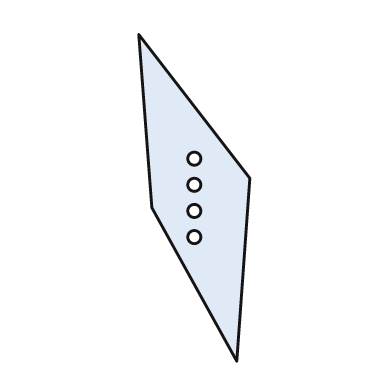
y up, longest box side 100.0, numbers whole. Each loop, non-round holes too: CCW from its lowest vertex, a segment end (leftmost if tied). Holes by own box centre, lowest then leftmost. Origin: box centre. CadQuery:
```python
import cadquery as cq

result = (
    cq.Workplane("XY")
    .moveTo(13.0, -50.0)
    .lineTo(17.0, 6.0)
    .lineTo(-17.0, 50.0)
    .lineTo(-13.0, -3.0)
    .close()
    .moveTo(0.0, -12.0)
    .circle(2.0)
    .moveTo(0.0, -4.0)
    .circle(2.0)
    .moveTo(0.0, 4.0)
    .circle(2.0)
    .moveTo(0.0, 12.0)
    .circle(2.0)
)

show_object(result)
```